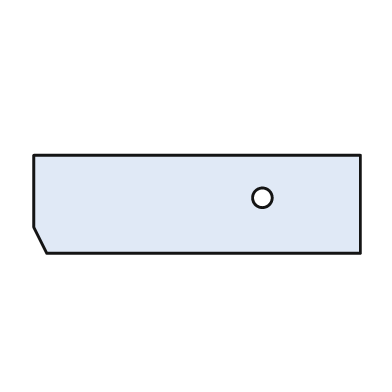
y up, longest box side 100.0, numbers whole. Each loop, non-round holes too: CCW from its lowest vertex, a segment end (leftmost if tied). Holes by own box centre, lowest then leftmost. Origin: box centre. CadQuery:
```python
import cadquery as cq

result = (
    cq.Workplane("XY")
    .moveTo(-46.0, -15.0)
    .lineTo(50.0, -15.0)
    .lineTo(50.0, 15.0)
    .lineTo(-50.0, 15.0)
    .lineTo(-50.0, -7.0)
    .close()
    .moveTo(20.0, 2.0)
    .circle(3.0)
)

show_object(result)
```